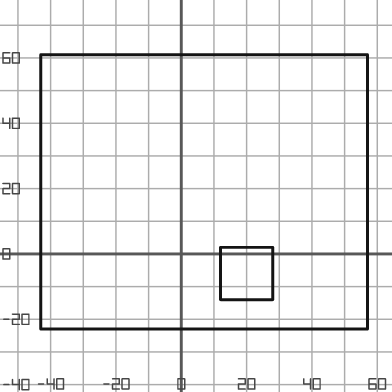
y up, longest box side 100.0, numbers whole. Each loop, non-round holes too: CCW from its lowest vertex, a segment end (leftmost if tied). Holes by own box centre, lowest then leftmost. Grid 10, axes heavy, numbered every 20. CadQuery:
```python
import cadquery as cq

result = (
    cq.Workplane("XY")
    .moveTo(-43.0, -23.0)
    .lineTo(57.0, -23.0)
    .lineTo(57.0, 61.0)
    .lineTo(-43.0, 61.0)
    .close()
    .moveTo(12.0, -14.0)
    .lineTo(28.0, -14.0)
    .lineTo(28.0, 2.0)
    .lineTo(12.0, 2.0)
    .close()
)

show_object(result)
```